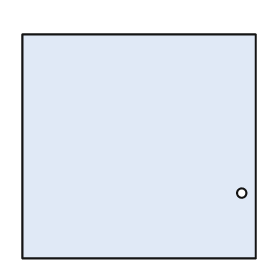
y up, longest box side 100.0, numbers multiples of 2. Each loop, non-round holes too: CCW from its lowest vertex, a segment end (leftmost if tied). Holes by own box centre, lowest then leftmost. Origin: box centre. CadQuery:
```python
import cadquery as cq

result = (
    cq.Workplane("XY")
    .moveTo(-50.0, -48.0)
    .lineTo(50.0, -48.0)
    .lineTo(50.0, 48.0)
    .lineTo(-50.0, 48.0)
    .close()
    .moveTo(44.0, -20.0)
    .circle(2.0)
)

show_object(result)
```